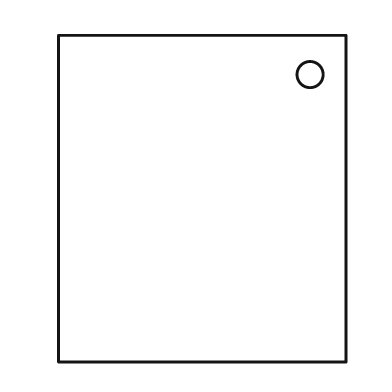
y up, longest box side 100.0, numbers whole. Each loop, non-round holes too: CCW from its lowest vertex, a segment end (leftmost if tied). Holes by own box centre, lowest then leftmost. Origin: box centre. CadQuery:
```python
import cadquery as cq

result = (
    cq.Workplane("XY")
    .moveTo(-44.0, -50.0)
    .lineTo(44.0, -50.0)
    .lineTo(44.0, 50.0)
    .lineTo(-44.0, 50.0)
    .close()
    .moveTo(33.0, 38.0)
    .circle(4.0)
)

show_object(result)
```